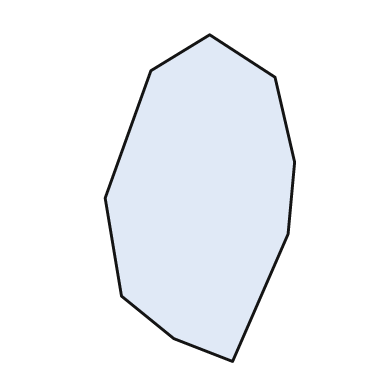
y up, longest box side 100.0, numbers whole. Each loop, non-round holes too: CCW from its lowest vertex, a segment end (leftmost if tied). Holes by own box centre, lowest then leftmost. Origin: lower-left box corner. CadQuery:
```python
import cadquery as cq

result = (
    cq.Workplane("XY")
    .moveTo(39.0, 0.0)
    .lineTo(56.0, 39.0)
    .lineTo(58.0, 61.0)
    .lineTo(52.0, 87.0)
    .lineTo(32.0, 100.0)
    .lineTo(14.0, 89.0)
    .lineTo(0.0, 50.0)
    .lineTo(5.0, 20.0)
    .lineTo(21.0, 7.0)
    .close()
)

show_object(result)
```